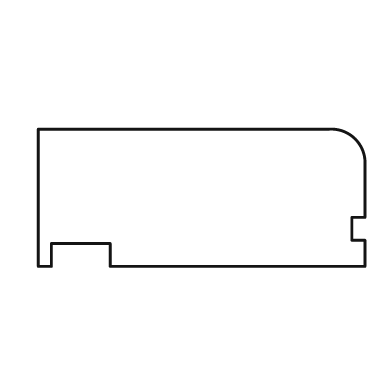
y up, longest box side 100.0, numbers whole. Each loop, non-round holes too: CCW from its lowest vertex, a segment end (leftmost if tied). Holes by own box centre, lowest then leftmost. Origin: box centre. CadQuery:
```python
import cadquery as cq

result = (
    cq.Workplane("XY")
    .moveTo(-50.0, -21.0)
    .lineTo(-46.0, -21.0)
    .lineTo(-46.0, -14.0)
    .lineTo(-28.0, -14.0)
    .lineTo(-28.0, -21.0)
    .lineTo(50.0, -21.0)
    .lineTo(50.0, -13.0)
    .lineTo(46.0, -13.0)
    .lineTo(46.0, -6.0)
    .lineTo(50.0, -6.0)
    .lineTo(50.0, 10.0)
    .threePointArc((47.0, 18.0), (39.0, 21.0))
    .lineTo(-50.0, 21.0)
    .close()
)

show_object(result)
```